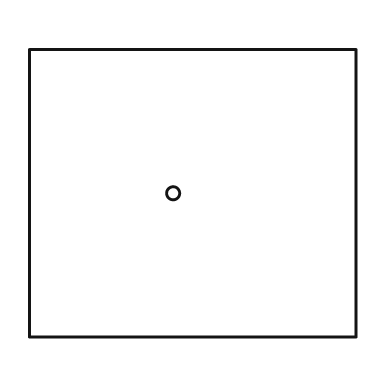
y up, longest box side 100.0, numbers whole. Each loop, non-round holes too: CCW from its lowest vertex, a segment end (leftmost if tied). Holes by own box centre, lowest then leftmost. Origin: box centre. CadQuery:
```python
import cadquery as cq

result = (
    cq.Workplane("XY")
    .moveTo(-50.0, -44.0)
    .lineTo(50.0, -44.0)
    .lineTo(50.0, 44.0)
    .lineTo(-50.0, 44.0)
    .close()
    .moveTo(-6.0, 0.0)
    .circle(2.0)
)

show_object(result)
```